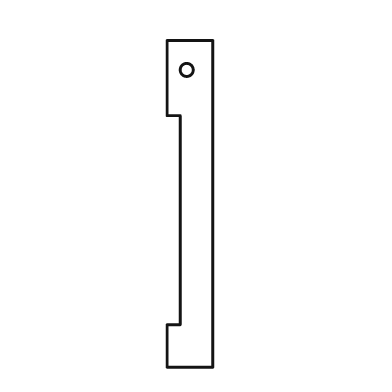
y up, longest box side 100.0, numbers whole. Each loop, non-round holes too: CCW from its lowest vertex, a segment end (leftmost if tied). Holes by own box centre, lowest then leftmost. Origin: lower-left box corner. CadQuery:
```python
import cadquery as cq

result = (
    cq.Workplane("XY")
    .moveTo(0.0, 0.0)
    .lineTo(14.0, 0.0)
    .lineTo(14.0, 100.0)
    .lineTo(0.0, 100.0)
    .lineTo(0.0, 77.0)
    .lineTo(4.0, 77.0)
    .lineTo(4.0, 13.0)
    .lineTo(0.0, 13.0)
    .close()
    .moveTo(6.0, 91.0)
    .circle(2.0)
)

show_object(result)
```